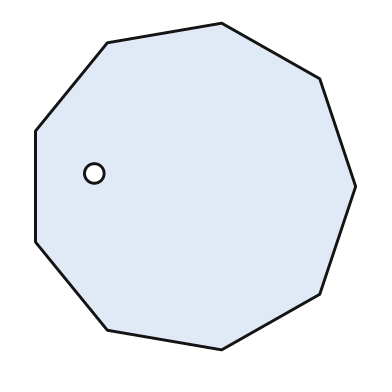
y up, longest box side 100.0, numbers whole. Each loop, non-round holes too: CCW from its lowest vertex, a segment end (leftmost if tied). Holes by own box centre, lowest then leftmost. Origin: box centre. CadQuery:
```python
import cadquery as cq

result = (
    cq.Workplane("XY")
    .moveTo(8.0, -50.0)
    .lineTo(38.0, -33.0)
    .lineTo(49.0, 0.0)
    .lineTo(38.0, 33.0)
    .lineTo(8.0, 50.0)
    .lineTo(-27.0, 44.0)
    .lineTo(-49.0, 17.0)
    .lineTo(-49.0, -17.0)
    .lineTo(-27.0, -44.0)
    .close()
    .moveTo(-31.0, 4.0)
    .circle(3.0)
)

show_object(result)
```